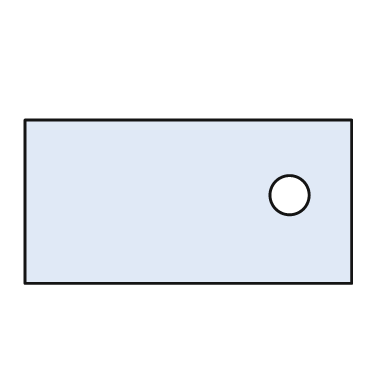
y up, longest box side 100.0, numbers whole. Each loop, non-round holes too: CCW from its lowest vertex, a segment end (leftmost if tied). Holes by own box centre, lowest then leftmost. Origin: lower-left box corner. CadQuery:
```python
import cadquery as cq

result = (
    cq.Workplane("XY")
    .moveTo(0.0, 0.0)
    .lineTo(100.0, 0.0)
    .lineTo(100.0, 50.0)
    .lineTo(0.0, 50.0)
    .close()
    .moveTo(81.0, 27.0)
    .circle(6.0)
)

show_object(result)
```